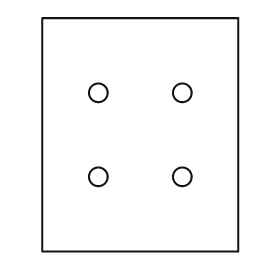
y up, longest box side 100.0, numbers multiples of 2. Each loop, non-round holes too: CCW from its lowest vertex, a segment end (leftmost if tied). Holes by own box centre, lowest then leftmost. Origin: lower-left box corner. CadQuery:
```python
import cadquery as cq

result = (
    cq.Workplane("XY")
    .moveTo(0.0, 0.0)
    .lineTo(84.0, 0.0)
    .lineTo(84.0, 100.0)
    .lineTo(0.0, 100.0)
    .close()
    .moveTo(24.0, 32.0)
    .circle(4.0)
    .moveTo(60.0, 32.0)
    .circle(4.0)
    .moveTo(24.0, 68.0)
    .circle(4.0)
    .moveTo(60.0, 68.0)
    .circle(4.0)
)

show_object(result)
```